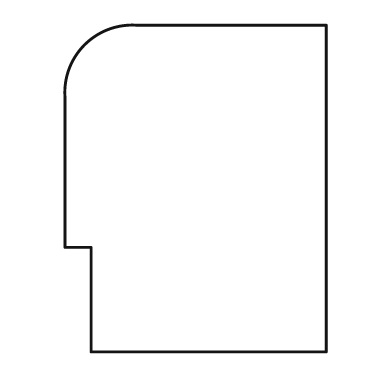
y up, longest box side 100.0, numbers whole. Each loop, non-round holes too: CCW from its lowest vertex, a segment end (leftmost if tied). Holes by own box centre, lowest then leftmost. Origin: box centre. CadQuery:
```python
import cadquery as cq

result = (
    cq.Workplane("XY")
    .moveTo(-32.0, -50.0)
    .lineTo(40.0, -50.0)
    .lineTo(40.0, 50.0)
    .lineTo(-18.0, 50.0)
    .threePointArc((-34.0, 44.0), (-40.0, 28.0))
    .lineTo(-40.0, -18.0)
    .lineTo(-32.0, -18.0)
    .close()
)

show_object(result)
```